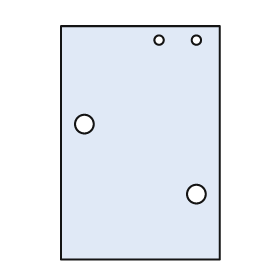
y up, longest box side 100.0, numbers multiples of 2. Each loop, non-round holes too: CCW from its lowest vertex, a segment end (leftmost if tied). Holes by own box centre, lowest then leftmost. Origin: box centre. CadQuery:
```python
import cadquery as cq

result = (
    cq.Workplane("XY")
    .moveTo(-34.0, -50.0)
    .lineTo(34.0, -50.0)
    .lineTo(34.0, 50.0)
    .lineTo(-34.0, 50.0)
    .close()
    .moveTo(24.0, -22.0)
    .circle(4.0)
    .moveTo(-24.0, 8.0)
    .circle(4.0)
    .moveTo(8.0, 44.0)
    .circle(2.0)
    .moveTo(24.0, 44.0)
    .circle(2.0)
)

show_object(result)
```